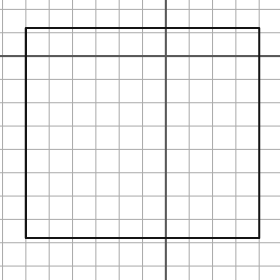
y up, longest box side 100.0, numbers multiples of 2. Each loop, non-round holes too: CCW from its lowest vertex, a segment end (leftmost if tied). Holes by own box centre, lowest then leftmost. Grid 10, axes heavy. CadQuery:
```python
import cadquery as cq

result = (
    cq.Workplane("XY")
    .moveTo(-60.0, -78.0)
    .lineTo(40.0, -78.0)
    .lineTo(40.0, 12.0)
    .lineTo(-60.0, 12.0)
    .close()
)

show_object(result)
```